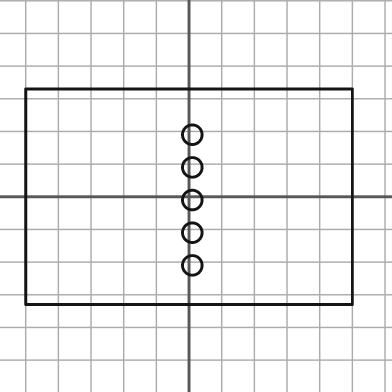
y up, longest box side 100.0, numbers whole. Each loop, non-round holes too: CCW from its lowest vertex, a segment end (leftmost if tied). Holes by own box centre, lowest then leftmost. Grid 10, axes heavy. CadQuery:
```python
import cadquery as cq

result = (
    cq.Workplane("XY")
    .moveTo(-50.0, -33.0)
    .lineTo(50.0, -33.0)
    .lineTo(50.0, 33.0)
    .lineTo(-50.0, 33.0)
    .close()
    .moveTo(1.0, -21.0)
    .circle(3.0)
    .moveTo(1.0, -11.0)
    .circle(3.0)
    .moveTo(1.0, -1.0)
    .circle(3.0)
    .moveTo(1.0, 9.0)
    .circle(3.0)
    .moveTo(1.0, 19.0)
    .circle(3.0)
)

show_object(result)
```